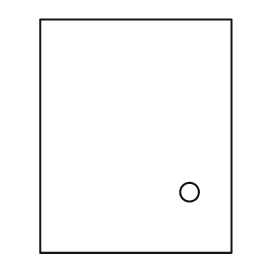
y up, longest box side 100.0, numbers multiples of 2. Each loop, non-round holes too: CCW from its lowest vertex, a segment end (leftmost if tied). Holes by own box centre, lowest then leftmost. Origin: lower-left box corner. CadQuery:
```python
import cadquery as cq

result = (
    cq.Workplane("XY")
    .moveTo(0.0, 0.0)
    .lineTo(82.0, 0.0)
    .lineTo(82.0, 100.0)
    .lineTo(0.0, 100.0)
    .close()
    .moveTo(64.0, 26.0)
    .circle(4.0)
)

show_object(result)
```